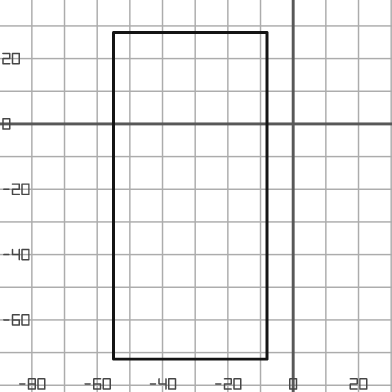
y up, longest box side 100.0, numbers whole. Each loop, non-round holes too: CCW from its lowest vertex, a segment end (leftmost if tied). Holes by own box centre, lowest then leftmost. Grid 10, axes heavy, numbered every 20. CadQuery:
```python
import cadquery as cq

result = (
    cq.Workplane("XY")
    .moveTo(-55.0, -72.0)
    .lineTo(-8.0, -72.0)
    .lineTo(-8.0, 28.0)
    .lineTo(-55.0, 28.0)
    .close()
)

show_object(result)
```